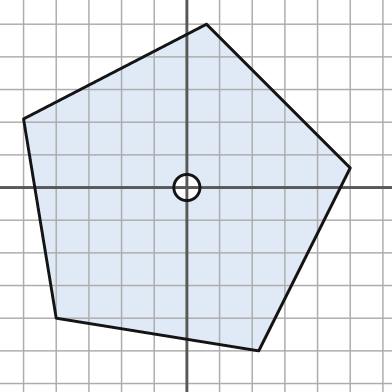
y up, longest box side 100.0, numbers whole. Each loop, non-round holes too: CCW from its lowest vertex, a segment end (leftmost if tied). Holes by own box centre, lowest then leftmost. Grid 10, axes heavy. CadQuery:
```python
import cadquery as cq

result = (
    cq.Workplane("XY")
    .moveTo(22.0, -50.0)
    .lineTo(50.0, 6.0)
    .lineTo(6.0, 50.0)
    .lineTo(-50.0, 21.0)
    .lineTo(-40.0, -40.0)
    .close()
    .moveTo(0.0, 0.0)
    .circle(4.0)
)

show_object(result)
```